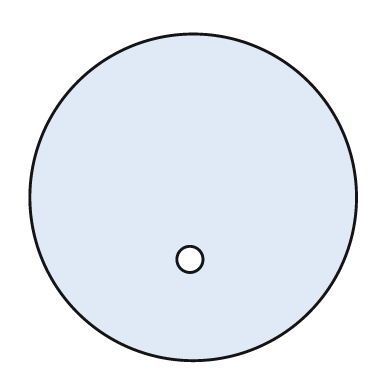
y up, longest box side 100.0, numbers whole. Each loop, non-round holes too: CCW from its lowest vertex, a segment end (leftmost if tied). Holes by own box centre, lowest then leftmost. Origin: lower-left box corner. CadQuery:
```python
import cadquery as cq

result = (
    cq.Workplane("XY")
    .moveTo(50.0, 50.0)
    .circle(50.0)
    .moveTo(49.0, 31.0)
    .circle(4.0)
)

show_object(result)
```